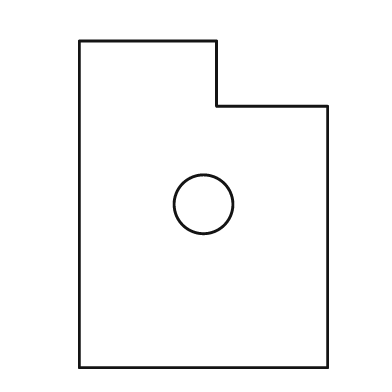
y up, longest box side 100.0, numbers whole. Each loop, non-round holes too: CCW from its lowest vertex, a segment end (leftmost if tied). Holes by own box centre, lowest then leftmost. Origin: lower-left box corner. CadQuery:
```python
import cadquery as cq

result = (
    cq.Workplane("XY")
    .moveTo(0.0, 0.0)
    .lineTo(76.0, 0.0)
    .lineTo(76.0, 80.0)
    .lineTo(42.0, 80.0)
    .lineTo(42.0, 100.0)
    .lineTo(0.0, 100.0)
    .close()
    .moveTo(38.0, 50.0)
    .circle(9.0)
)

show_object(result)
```